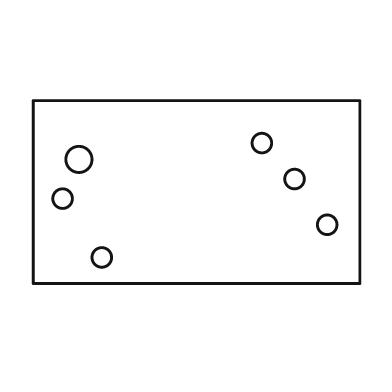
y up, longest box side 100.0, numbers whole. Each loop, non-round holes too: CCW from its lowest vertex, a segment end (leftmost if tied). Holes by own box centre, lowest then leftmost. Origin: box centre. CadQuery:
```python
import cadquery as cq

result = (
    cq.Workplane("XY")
    .moveTo(-50.0, -28.0)
    .lineTo(50.0, -28.0)
    .lineTo(50.0, 28.0)
    .lineTo(-50.0, 28.0)
    .close()
    .moveTo(-29.0, -20.0)
    .circle(3.0)
    .moveTo(40.0, -10.0)
    .circle(3.0)
    .moveTo(-41.0, -2.0)
    .circle(3.0)
    .moveTo(30.0, 4.0)
    .circle(3.0)
    .moveTo(-36.0, 10.0)
    .circle(4.0)
    .moveTo(20.0, 15.0)
    .circle(3.0)
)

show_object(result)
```